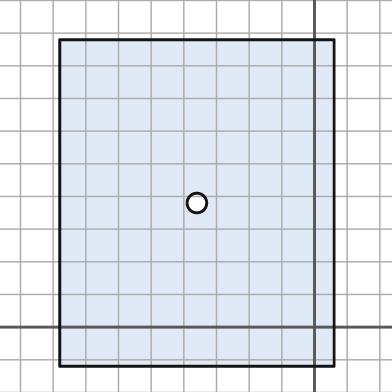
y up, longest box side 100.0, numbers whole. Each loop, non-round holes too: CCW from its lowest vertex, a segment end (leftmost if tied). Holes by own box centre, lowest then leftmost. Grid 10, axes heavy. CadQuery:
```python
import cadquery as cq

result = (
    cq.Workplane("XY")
    .moveTo(-78.0, -12.0)
    .lineTo(6.0, -12.0)
    .lineTo(6.0, 88.0)
    .lineTo(-78.0, 88.0)
    .close()
    .moveTo(-36.0, 38.0)
    .circle(3.0)
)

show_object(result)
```